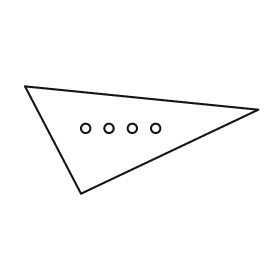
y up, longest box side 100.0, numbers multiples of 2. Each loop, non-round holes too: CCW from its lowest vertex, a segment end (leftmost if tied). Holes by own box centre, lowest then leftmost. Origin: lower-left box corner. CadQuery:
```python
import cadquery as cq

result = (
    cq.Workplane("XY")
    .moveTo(24.0, 0.0)
    .lineTo(100.0, 36.0)
    .lineTo(0.0, 46.0)
    .close()
    .moveTo(26.0, 28.0)
    .circle(2.0)
    .moveTo(36.0, 28.0)
    .circle(2.0)
    .moveTo(46.0, 28.0)
    .circle(2.0)
    .moveTo(56.0, 28.0)
    .circle(2.0)
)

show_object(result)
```